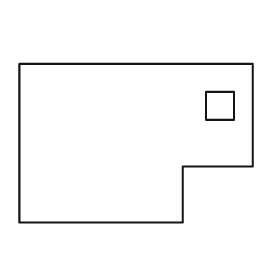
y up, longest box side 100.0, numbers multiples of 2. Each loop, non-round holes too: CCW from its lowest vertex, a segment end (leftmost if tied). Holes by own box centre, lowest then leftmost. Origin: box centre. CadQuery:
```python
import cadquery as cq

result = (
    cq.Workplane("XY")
    .moveTo(-50.0, -34.0)
    .lineTo(20.0, -34.0)
    .lineTo(20.0, -10.0)
    .lineTo(50.0, -10.0)
    .lineTo(50.0, 34.0)
    .lineTo(-50.0, 34.0)
    .close()
    .moveTo(30.0, 10.0)
    .lineTo(42.0, 10.0)
    .lineTo(42.0, 22.0)
    .lineTo(30.0, 22.0)
    .close()
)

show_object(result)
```